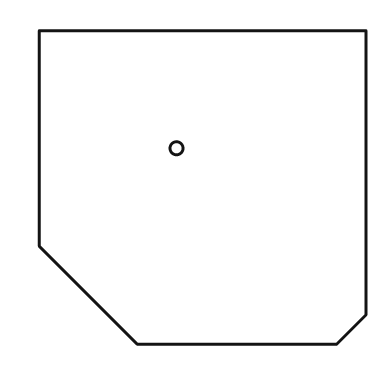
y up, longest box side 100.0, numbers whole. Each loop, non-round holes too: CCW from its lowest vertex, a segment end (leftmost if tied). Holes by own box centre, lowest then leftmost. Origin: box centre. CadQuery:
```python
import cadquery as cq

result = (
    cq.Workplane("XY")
    .moveTo(-20.0, -48.0)
    .lineTo(41.0, -48.0)
    .lineTo(50.0, -39.0)
    .lineTo(50.0, 48.0)
    .lineTo(-50.0, 48.0)
    .lineTo(-50.0, -18.0)
    .close()
    .moveTo(-8.0, 12.0)
    .circle(2.0)
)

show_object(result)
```